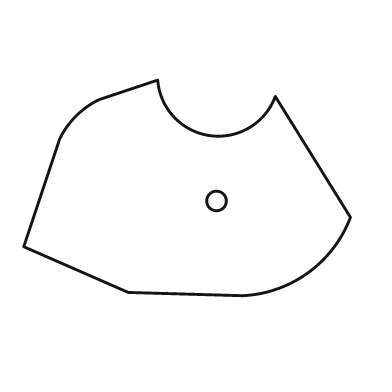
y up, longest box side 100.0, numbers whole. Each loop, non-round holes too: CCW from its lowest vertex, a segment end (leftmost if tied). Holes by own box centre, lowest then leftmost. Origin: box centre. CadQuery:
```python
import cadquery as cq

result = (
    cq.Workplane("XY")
    .moveTo(17.0, -33.0)
    .threePointArc((37.0, -26.0), (50.0, -9.0))
    .lineTo(27.0, 28.0)
    .threePointArc((7.0, 16.0), (-9.0, 33.0))
    .lineTo(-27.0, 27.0)
    .threePointArc((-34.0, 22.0), (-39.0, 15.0))
    .lineTo(-50.0, -18.0)
    .lineTo(-18.0, -32.0)
    .close()
    .moveTo(9.0, -4.0)
    .circle(3.0)
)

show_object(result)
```